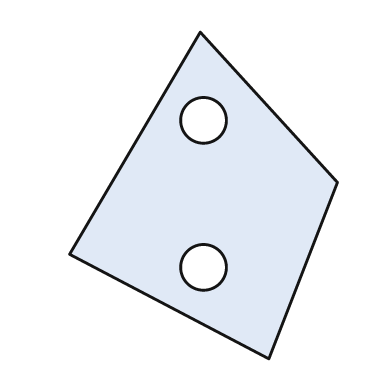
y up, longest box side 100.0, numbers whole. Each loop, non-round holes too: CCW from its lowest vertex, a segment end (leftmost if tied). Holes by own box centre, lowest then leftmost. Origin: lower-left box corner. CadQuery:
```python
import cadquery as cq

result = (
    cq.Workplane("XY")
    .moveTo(61.0, 0.0)
    .lineTo(82.0, 54.0)
    .lineTo(40.0, 100.0)
    .lineTo(0.0, 32.0)
    .close()
    .moveTo(41.0, 28.0)
    .circle(7.0)
    .moveTo(41.0, 73.0)
    .circle(7.0)
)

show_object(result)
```